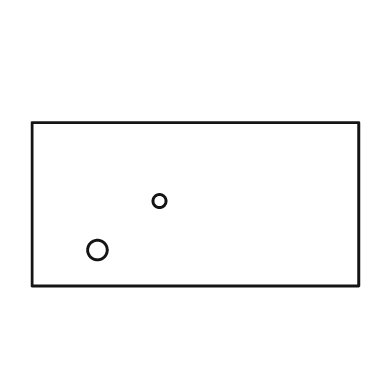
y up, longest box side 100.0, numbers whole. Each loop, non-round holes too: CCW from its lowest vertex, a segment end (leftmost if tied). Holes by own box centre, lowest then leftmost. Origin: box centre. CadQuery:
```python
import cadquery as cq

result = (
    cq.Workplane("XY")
    .moveTo(-50.0, -25.0)
    .lineTo(50.0, -25.0)
    .lineTo(50.0, 25.0)
    .lineTo(-50.0, 25.0)
    .close()
    .moveTo(-30.0, -14.0)
    .circle(3.0)
    .moveTo(-11.0, 1.0)
    .circle(2.0)
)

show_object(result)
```